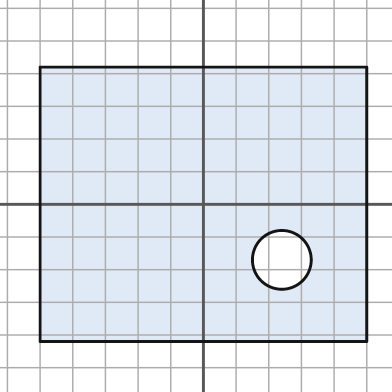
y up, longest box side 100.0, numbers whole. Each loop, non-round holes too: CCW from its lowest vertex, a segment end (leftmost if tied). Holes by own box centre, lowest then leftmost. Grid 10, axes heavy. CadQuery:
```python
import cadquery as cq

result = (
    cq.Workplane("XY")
    .moveTo(-50.0, -42.0)
    .lineTo(50.0, -42.0)
    .lineTo(50.0, 42.0)
    .lineTo(-50.0, 42.0)
    .close()
    .moveTo(24.0, -17.0)
    .circle(9.0)
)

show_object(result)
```